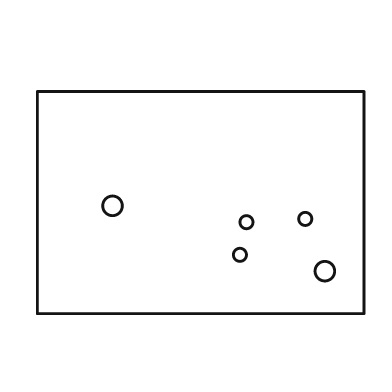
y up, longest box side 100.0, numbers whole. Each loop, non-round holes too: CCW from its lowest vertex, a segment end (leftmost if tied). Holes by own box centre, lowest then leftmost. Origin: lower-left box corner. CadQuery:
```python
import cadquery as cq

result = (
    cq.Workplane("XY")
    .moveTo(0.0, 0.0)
    .lineTo(100.0, 0.0)
    .lineTo(100.0, 68.0)
    .lineTo(0.0, 68.0)
    .close()
    .moveTo(88.0, 13.0)
    .circle(3.0)
    .moveTo(62.0, 18.0)
    .circle(2.0)
    .moveTo(64.0, 28.0)
    .circle(2.0)
    .moveTo(82.0, 29.0)
    .circle(2.0)
    .moveTo(23.0, 33.0)
    .circle(3.0)
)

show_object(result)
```